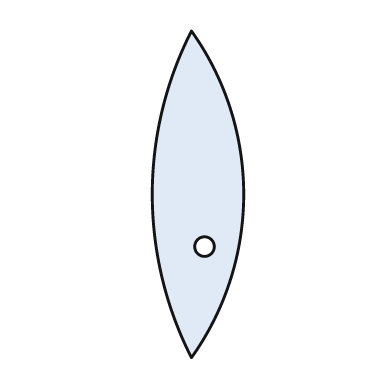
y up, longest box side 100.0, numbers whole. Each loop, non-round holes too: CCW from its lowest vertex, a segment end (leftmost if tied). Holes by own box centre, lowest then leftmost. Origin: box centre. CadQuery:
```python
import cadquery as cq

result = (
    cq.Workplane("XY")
    .moveTo(-2.0, -50.0)
    .threePointArc((14.0, 0.0), (-2.0, 50.0))
    .threePointArc((-14.0, 0.0), (-2.0, -50.0))
    .close()
    .moveTo(2.0, -16.0)
    .circle(3.0)
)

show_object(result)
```